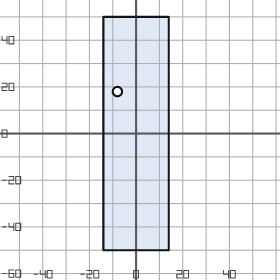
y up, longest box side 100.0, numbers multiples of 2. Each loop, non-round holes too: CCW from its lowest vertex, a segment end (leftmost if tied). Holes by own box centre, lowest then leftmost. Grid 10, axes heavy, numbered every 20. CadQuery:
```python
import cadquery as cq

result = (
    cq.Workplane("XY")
    .moveTo(-14.0, -50.0)
    .lineTo(14.0, -50.0)
    .lineTo(14.0, 50.0)
    .lineTo(-14.0, 50.0)
    .close()
    .moveTo(-8.0, 18.0)
    .circle(2.0)
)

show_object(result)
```